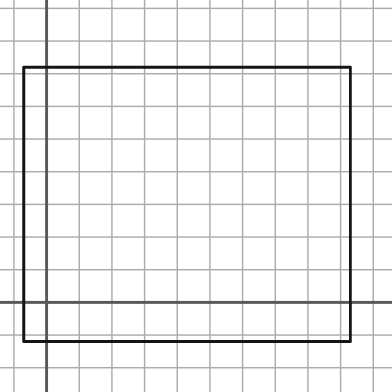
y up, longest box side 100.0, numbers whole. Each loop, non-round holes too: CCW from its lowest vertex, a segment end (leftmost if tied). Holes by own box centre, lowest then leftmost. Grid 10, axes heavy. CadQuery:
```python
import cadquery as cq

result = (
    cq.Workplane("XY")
    .moveTo(-7.0, -12.0)
    .lineTo(93.0, -12.0)
    .lineTo(93.0, 72.0)
    .lineTo(-7.0, 72.0)
    .close()
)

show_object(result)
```